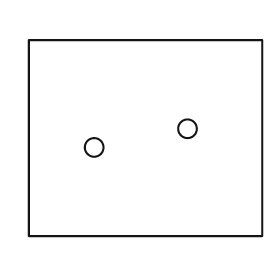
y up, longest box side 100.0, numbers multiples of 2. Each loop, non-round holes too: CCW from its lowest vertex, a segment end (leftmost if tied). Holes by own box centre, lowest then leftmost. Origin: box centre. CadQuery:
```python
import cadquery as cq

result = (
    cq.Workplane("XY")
    .moveTo(-50.0, -42.0)
    .lineTo(50.0, -42.0)
    .lineTo(50.0, 42.0)
    .lineTo(-50.0, 42.0)
    .close()
    .moveTo(-22.0, -4.0)
    .circle(4.0)
    .moveTo(18.0, 4.0)
    .circle(4.0)
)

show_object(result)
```